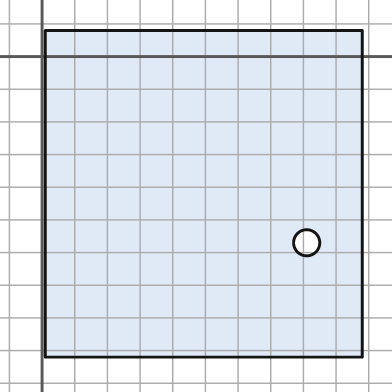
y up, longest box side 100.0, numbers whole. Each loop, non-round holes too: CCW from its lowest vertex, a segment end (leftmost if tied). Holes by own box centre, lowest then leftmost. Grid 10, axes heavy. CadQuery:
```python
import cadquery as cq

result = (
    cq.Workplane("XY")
    .moveTo(1.0, -92.0)
    .lineTo(98.0, -92.0)
    .lineTo(98.0, 8.0)
    .lineTo(1.0, 8.0)
    .close()
    .moveTo(81.0, -57.0)
    .circle(4.0)
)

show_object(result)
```